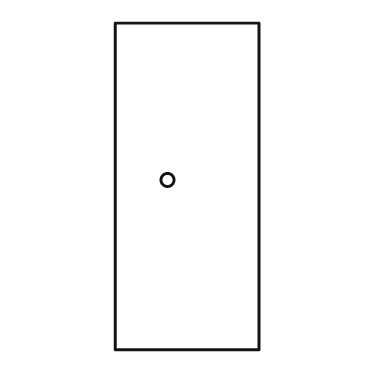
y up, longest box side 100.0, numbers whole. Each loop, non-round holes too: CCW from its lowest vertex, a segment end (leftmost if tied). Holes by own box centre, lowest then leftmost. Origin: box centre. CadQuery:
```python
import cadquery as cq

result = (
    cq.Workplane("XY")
    .moveTo(-22.0, -50.0)
    .lineTo(22.0, -50.0)
    .lineTo(22.0, 50.0)
    .lineTo(-22.0, 50.0)
    .close()
    .moveTo(-6.0, 2.0)
    .circle(2.0)
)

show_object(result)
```